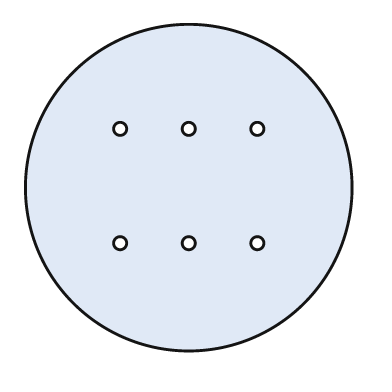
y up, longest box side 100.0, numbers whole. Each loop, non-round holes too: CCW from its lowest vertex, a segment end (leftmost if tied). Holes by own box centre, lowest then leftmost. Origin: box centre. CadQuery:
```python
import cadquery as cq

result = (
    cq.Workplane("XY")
    .moveTo(0.0, 0.0)
    .circle(50.0)
    .moveTo(-21.0, -17.0)
    .circle(2.0)
    .moveTo(0.0, -17.0)
    .circle(2.0)
    .moveTo(21.0, -17.0)
    .circle(2.0)
    .moveTo(-21.0, 18.0)
    .circle(2.0)
    .moveTo(0.0, 18.0)
    .circle(2.0)
    .moveTo(21.0, 18.0)
    .circle(2.0)
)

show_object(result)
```